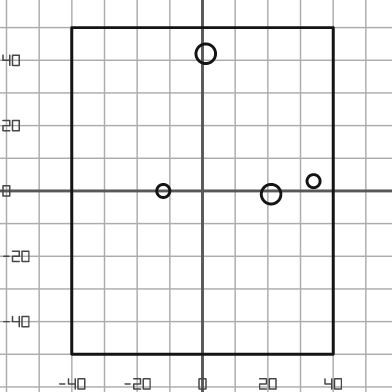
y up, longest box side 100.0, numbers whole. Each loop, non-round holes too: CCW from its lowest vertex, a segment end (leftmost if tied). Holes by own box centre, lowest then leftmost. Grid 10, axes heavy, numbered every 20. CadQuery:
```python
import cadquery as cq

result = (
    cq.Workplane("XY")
    .moveTo(-40.0, -50.0)
    .lineTo(40.0, -50.0)
    .lineTo(40.0, 50.0)
    .lineTo(-40.0, 50.0)
    .close()
    .moveTo(21.0, -1.0)
    .circle(3.0)
    .moveTo(-12.0, 0.0)
    .circle(2.0)
    .moveTo(34.0, 3.0)
    .circle(2.0)
    .moveTo(1.0, 42.0)
    .circle(3.0)
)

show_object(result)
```